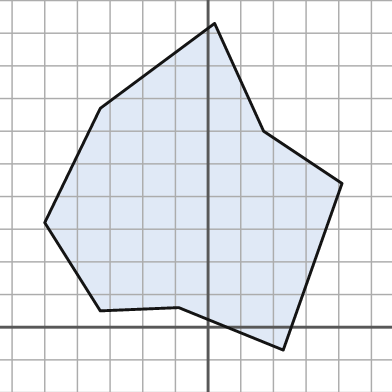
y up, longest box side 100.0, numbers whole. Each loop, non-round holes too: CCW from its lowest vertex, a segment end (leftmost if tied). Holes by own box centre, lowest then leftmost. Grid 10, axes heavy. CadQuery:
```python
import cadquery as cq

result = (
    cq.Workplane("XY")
    .moveTo(23.0, -7.0)
    .lineTo(41.0, 44.0)
    .lineTo(17.0, 60.0)
    .lineTo(2.0, 93.0)
    .lineTo(-33.0, 67.0)
    .lineTo(-50.0, 32.0)
    .lineTo(-33.0, 5.0)
    .lineTo(-9.0, 6.0)
    .close()
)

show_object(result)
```